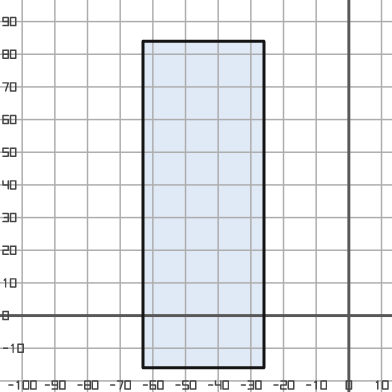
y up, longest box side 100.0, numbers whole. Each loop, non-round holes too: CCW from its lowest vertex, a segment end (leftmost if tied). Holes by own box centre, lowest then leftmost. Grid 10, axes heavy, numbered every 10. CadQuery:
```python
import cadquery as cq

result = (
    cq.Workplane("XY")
    .moveTo(-63.0, -16.0)
    .lineTo(-26.0, -16.0)
    .lineTo(-26.0, 84.0)
    .lineTo(-63.0, 84.0)
    .close()
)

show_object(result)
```